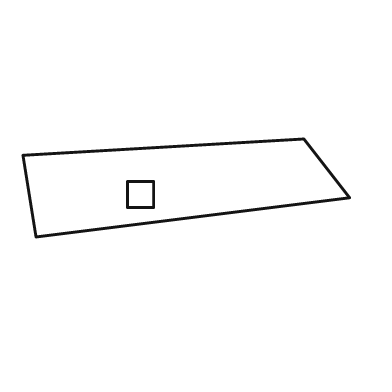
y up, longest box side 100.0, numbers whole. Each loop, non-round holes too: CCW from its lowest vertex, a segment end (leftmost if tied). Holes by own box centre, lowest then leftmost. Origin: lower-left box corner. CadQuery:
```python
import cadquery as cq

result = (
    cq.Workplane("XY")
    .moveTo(4.0, 0.0)
    .lineTo(100.0, 12.0)
    .lineTo(86.0, 30.0)
    .lineTo(0.0, 25.0)
    .close()
    .moveTo(32.0, 9.0)
    .lineTo(40.0, 9.0)
    .lineTo(40.0, 17.0)
    .lineTo(32.0, 17.0)
    .close()
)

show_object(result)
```